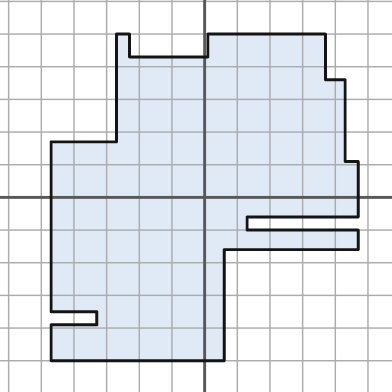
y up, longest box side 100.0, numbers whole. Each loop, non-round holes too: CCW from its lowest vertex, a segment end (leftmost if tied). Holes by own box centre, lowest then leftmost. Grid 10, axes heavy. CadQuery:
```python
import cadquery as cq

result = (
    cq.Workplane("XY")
    .moveTo(-47.0, -50.0)
    .lineTo(6.0, -50.0)
    .lineTo(6.0, -16.0)
    .lineTo(47.0, -16.0)
    .lineTo(47.0, -10.0)
    .lineTo(13.0, -10.0)
    .lineTo(13.0, -6.0)
    .lineTo(47.0, -6.0)
    .lineTo(47.0, 11.0)
    .lineTo(43.0, 11.0)
    .lineTo(43.0, 36.0)
    .lineTo(37.0, 36.0)
    .lineTo(37.0, 50.0)
    .lineTo(1.0, 50.0)
    .lineTo(1.0, 43.0)
    .lineTo(-23.0, 43.0)
    .lineTo(-23.0, 50.0)
    .lineTo(-27.0, 50.0)
    .lineTo(-27.0, 17.0)
    .lineTo(-47.0, 17.0)
    .lineTo(-47.0, -35.0)
    .lineTo(-33.0, -35.0)
    .lineTo(-33.0, -39.0)
    .lineTo(-47.0, -39.0)
    .close()
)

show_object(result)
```